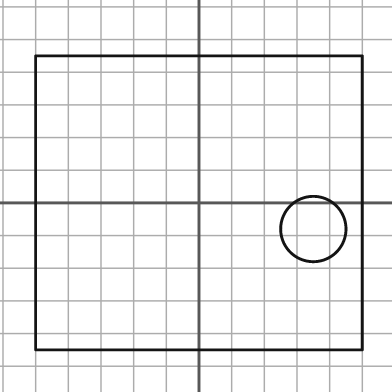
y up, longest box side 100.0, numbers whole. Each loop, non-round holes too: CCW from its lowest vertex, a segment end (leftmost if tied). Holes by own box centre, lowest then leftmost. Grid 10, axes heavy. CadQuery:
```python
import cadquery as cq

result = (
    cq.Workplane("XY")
    .moveTo(-50.0, -45.0)
    .lineTo(50.0, -45.0)
    .lineTo(50.0, 45.0)
    .lineTo(-50.0, 45.0)
    .close()
    .moveTo(35.0, -8.0)
    .circle(10.0)
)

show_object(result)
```